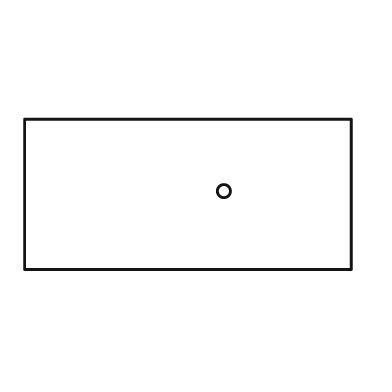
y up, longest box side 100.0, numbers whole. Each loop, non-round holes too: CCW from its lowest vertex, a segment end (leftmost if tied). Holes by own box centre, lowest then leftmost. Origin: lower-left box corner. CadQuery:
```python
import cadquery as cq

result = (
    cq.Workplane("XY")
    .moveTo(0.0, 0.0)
    .lineTo(100.0, 0.0)
    .lineTo(100.0, 46.0)
    .lineTo(0.0, 46.0)
    .close()
    .moveTo(61.0, 24.0)
    .circle(2.0)
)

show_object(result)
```